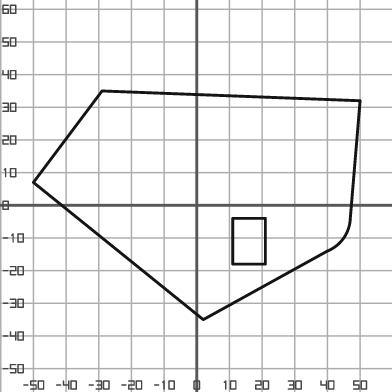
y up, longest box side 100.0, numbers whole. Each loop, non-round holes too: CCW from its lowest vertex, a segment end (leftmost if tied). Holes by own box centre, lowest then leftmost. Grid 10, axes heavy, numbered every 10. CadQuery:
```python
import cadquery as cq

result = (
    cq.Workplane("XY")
    .moveTo(2.0, -35.0)
    .lineTo(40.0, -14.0)
    .threePointArc((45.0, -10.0), (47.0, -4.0))
    .lineTo(50.0, 32.0)
    .lineTo(-29.0, 35.0)
    .lineTo(-50.0, 7.0)
    .close()
    .moveTo(11.0, -18.0)
    .lineTo(21.0, -18.0)
    .lineTo(21.0, -4.0)
    .lineTo(11.0, -4.0)
    .close()
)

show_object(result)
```